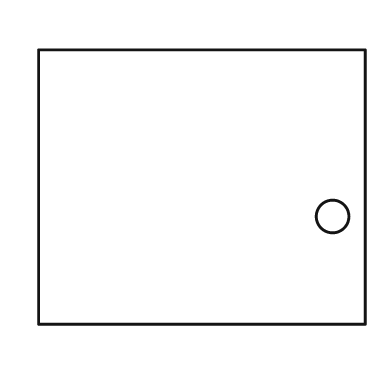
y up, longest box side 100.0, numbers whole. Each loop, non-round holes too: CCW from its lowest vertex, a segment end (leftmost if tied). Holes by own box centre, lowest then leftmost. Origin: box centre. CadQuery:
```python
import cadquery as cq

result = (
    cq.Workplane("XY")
    .moveTo(-50.0, -42.0)
    .lineTo(50.0, -42.0)
    .lineTo(50.0, 42.0)
    .lineTo(-50.0, 42.0)
    .close()
    .moveTo(40.0, -9.0)
    .circle(5.0)
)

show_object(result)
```